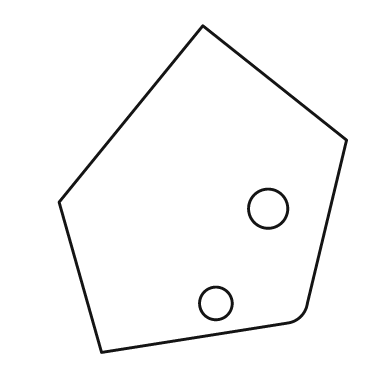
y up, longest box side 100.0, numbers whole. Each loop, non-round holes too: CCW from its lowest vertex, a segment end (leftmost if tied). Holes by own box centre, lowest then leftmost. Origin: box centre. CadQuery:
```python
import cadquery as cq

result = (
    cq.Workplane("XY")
    .moveTo(-31.0, -50.0)
    .lineTo(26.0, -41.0)
    .threePointArc((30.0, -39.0), (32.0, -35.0))
    .lineTo(44.0, 15.0)
    .lineTo(0.0, 50.0)
    .lineTo(-44.0, -4.0)
    .close()
    .moveTo(4.0, -35.0)
    .circle(5.0)
    .moveTo(20.0, -6.0)
    .circle(6.0)
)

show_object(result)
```